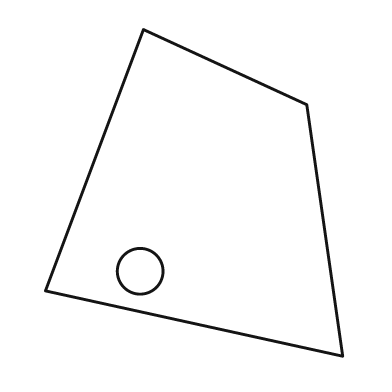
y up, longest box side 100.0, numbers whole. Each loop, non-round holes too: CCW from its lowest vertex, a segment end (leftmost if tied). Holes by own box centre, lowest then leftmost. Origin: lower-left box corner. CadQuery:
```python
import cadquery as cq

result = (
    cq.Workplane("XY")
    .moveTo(91.0, 0.0)
    .lineTo(80.0, 77.0)
    .lineTo(30.0, 100.0)
    .lineTo(0.0, 20.0)
    .close()
    .moveTo(29.0, 26.0)
    .circle(7.0)
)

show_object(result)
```